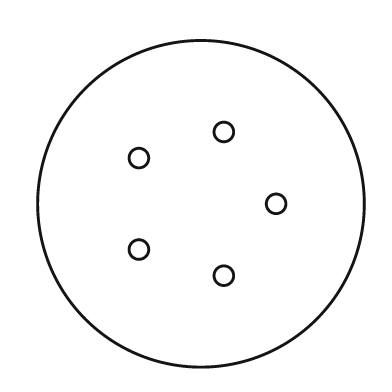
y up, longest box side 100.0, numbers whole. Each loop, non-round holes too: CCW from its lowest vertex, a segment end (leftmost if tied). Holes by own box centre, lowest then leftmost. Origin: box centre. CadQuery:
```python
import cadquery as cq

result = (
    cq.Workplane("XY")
    .moveTo(0.0, 0.0)
    .circle(50.0)
    .moveTo(7.0, -22.0)
    .circle(3.0)
    .moveTo(-19.0, -14.0)
    .circle(3.0)
    .moveTo(23.0, 0.0)
    .circle(3.0)
    .moveTo(-19.0, 14.0)
    .circle(3.0)
    .moveTo(7.0, 22.0)
    .circle(3.0)
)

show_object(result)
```